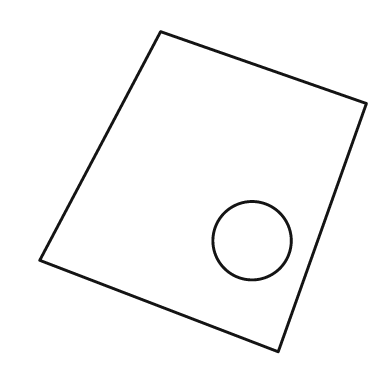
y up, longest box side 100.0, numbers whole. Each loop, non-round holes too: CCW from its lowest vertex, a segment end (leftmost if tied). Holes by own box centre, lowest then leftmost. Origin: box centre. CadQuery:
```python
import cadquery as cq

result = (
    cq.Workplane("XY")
    .moveTo(23.0, -49.0)
    .lineTo(50.0, 27.0)
    .lineTo(-13.0, 49.0)
    .lineTo(-50.0, -21.0)
    .close()
    .moveTo(15.0, -15.0)
    .circle(12.0)
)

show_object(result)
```